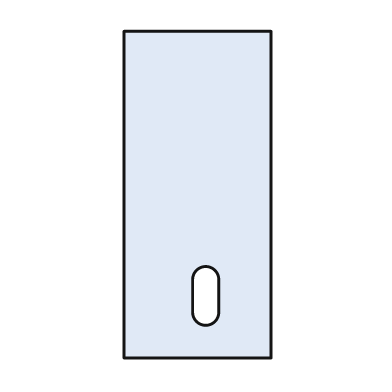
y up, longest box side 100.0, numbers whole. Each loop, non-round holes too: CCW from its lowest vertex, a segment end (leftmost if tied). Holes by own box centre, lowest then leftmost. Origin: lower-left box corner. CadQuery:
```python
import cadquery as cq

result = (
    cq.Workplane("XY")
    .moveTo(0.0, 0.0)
    .lineTo(45.0, 0.0)
    .lineTo(45.0, 100.0)
    .lineTo(0.0, 100.0)
    .close()
    .moveTo(21.0, 14.0)
    .threePointArc((25.0, 10.0), (29.0, 14.0))
    .lineTo(29.0, 24.0)
    .threePointArc((25.0, 28.0), (21.0, 24.0))
    .close()
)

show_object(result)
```